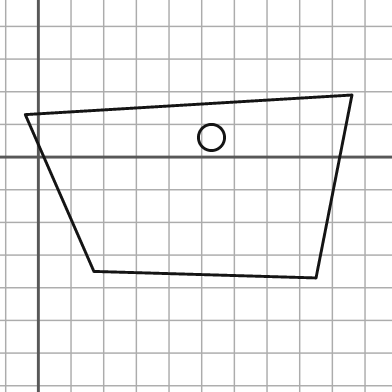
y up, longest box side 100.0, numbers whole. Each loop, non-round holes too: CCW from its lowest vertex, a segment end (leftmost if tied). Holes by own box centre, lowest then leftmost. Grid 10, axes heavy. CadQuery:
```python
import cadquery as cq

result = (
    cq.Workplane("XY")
    .moveTo(85.0, -37.0)
    .lineTo(96.0, 19.0)
    .lineTo(-4.0, 13.0)
    .lineTo(17.0, -35.0)
    .close()
    .moveTo(53.0, 6.0)
    .circle(4.0)
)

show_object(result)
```